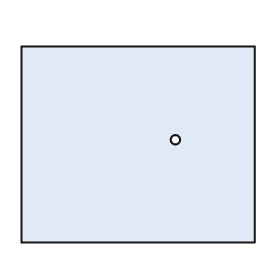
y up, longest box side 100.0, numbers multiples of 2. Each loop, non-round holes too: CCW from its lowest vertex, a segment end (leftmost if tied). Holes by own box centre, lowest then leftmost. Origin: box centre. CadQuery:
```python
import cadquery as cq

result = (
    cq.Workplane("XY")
    .moveTo(-50.0, -42.0)
    .lineTo(50.0, -42.0)
    .lineTo(50.0, 42.0)
    .lineTo(-50.0, 42.0)
    .close()
    .moveTo(16.0, 2.0)
    .circle(2.0)
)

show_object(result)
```